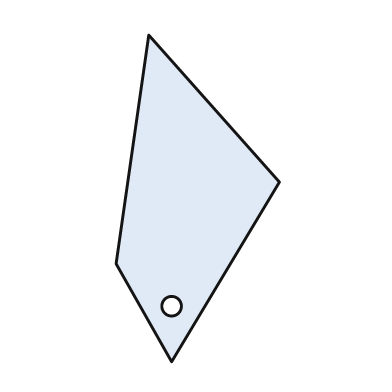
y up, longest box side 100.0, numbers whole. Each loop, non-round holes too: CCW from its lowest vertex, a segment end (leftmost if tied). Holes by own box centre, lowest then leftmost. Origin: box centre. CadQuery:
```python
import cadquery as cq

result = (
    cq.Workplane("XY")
    .moveTo(-8.0, -50.0)
    .lineTo(25.0, 5.0)
    .lineTo(-15.0, 50.0)
    .lineTo(-25.0, -20.0)
    .close()
    .moveTo(-8.0, -33.0)
    .circle(3.0)
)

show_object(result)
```